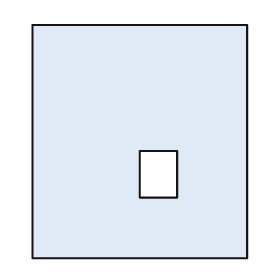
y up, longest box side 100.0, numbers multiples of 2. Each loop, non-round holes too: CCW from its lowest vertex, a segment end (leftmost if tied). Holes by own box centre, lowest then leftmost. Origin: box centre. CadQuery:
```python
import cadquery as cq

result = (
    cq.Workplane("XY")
    .moveTo(-46.0, -50.0)
    .lineTo(46.0, -50.0)
    .lineTo(46.0, 50.0)
    .lineTo(-46.0, 50.0)
    .close()
    .moveTo(0.0, -24.0)
    .lineTo(16.0, -24.0)
    .lineTo(16.0, -4.0)
    .lineTo(0.0, -4.0)
    .close()
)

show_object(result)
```